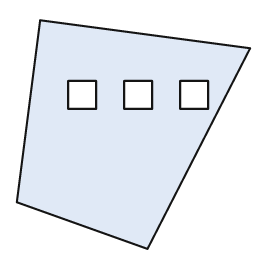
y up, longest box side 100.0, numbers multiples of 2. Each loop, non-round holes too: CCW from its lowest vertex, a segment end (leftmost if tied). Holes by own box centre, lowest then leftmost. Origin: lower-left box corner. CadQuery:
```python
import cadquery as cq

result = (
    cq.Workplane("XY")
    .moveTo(56.0, 0.0)
    .lineTo(100.0, 86.0)
    .lineTo(10.0, 98.0)
    .lineTo(0.0, 20.0)
    .close()
    .moveTo(22.0, 60.0)
    .lineTo(34.0, 60.0)
    .lineTo(34.0, 72.0)
    .lineTo(22.0, 72.0)
    .close()
    .moveTo(46.0, 60.0)
    .lineTo(58.0, 60.0)
    .lineTo(58.0, 72.0)
    .lineTo(46.0, 72.0)
    .close()
    .moveTo(70.0, 60.0)
    .lineTo(82.0, 60.0)
    .lineTo(82.0, 72.0)
    .lineTo(70.0, 72.0)
    .close()
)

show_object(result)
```